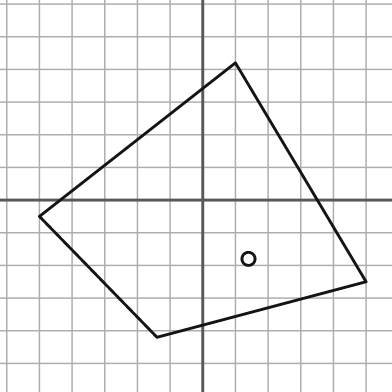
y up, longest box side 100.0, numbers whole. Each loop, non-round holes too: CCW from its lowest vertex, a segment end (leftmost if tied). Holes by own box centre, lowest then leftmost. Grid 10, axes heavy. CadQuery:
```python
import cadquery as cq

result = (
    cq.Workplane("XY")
    .moveTo(-14.0, -42.0)
    .lineTo(50.0, -25.0)
    .lineTo(10.0, 42.0)
    .lineTo(-50.0, -5.0)
    .close()
    .moveTo(14.0, -18.0)
    .circle(2.0)
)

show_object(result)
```